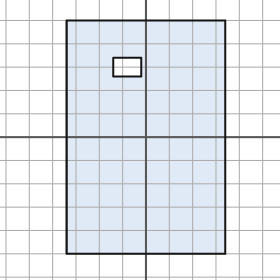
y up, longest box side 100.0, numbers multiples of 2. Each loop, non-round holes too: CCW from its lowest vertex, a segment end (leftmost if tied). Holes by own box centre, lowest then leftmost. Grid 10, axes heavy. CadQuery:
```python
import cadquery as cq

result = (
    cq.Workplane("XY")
    .moveTo(-34.0, -50.0)
    .lineTo(34.0, -50.0)
    .lineTo(34.0, 50.0)
    .lineTo(-34.0, 50.0)
    .close()
    .moveTo(-14.0, 26.0)
    .lineTo(-2.0, 26.0)
    .lineTo(-2.0, 34.0)
    .lineTo(-14.0, 34.0)
    .close()
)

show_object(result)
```